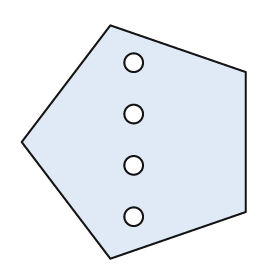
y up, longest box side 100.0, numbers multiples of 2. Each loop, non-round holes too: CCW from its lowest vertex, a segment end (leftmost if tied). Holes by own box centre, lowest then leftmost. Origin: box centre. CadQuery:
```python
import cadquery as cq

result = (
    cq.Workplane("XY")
    .moveTo(-10.0, -50.0)
    .lineTo(48.0, -30.0)
    .lineTo(48.0, 30.0)
    .lineTo(-10.0, 50.0)
    .lineTo(-48.0, 0.0)
    .close()
    .moveTo(0.0, -32.0)
    .circle(4.0)
    .moveTo(0.0, -10.0)
    .circle(4.0)
    .moveTo(0.0, 12.0)
    .circle(4.0)
    .moveTo(0.0, 34.0)
    .circle(4.0)
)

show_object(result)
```